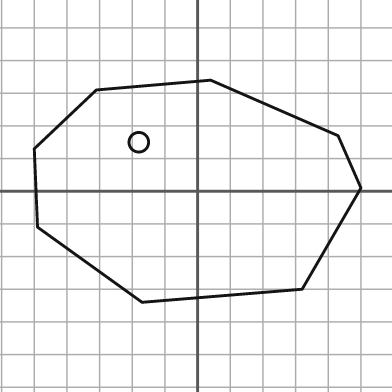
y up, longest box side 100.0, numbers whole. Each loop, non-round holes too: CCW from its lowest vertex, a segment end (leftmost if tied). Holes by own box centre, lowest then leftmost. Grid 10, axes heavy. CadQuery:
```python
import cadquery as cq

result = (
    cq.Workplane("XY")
    .moveTo(-17.0, -34.0)
    .lineTo(32.0, -30.0)
    .lineTo(50.0, 1.0)
    .lineTo(43.0, 17.0)
    .lineTo(4.0, 34.0)
    .lineTo(-31.0, 31.0)
    .lineTo(-50.0, 13.0)
    .lineTo(-49.0, -11.0)
    .close()
    .moveTo(-18.0, 15.0)
    .circle(3.0)
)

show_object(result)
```